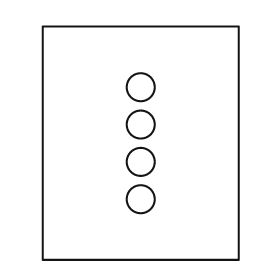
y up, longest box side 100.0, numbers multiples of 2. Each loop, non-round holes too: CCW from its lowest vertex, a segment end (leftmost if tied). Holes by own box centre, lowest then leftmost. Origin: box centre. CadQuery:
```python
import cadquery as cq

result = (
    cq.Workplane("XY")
    .moveTo(-42.0, -50.0)
    .lineTo(42.0, -50.0)
    .lineTo(42.0, 50.0)
    .lineTo(-42.0, 50.0)
    .close()
    .moveTo(0.0, -24.0)
    .circle(6.0)
    .moveTo(0.0, -8.0)
    .circle(6.0)
    .moveTo(0.0, 8.0)
    .circle(6.0)
    .moveTo(0.0, 24.0)
    .circle(6.0)
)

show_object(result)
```